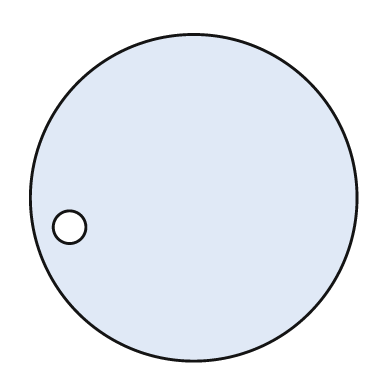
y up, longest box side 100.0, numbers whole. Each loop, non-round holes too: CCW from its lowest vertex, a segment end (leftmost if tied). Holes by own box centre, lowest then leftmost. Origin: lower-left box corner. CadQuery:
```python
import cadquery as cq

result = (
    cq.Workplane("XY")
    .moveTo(50.0, 50.0)
    .circle(50.0)
    .moveTo(12.0, 41.0)
    .circle(5.0)
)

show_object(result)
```